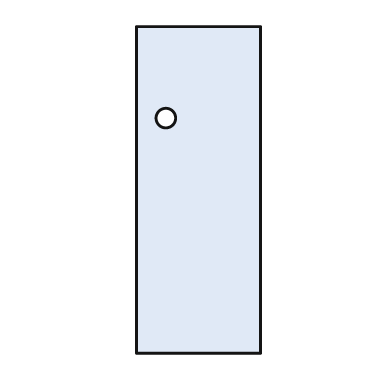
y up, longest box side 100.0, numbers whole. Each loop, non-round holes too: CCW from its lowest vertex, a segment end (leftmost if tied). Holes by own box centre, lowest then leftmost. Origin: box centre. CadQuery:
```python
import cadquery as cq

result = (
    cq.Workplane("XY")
    .moveTo(-19.0, -50.0)
    .lineTo(19.0, -50.0)
    .lineTo(19.0, 50.0)
    .lineTo(-19.0, 50.0)
    .close()
    .moveTo(-10.0, 22.0)
    .circle(3.0)
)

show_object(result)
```